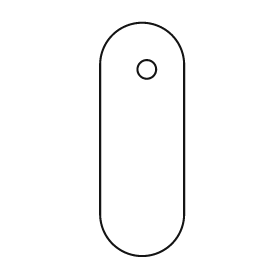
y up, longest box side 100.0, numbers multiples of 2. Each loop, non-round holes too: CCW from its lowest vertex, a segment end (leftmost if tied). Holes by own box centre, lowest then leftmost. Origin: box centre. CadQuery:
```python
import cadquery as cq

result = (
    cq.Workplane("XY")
    .moveTo(-18.0, -32.0)
    .threePointArc((0.0, -50.0), (18.0, -32.0))
    .lineTo(18.0, 32.0)
    .threePointArc((0.0, 50.0), (-18.0, 32.0))
    .close()
    .moveTo(2.0, 30.0)
    .circle(4.0)
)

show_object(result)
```